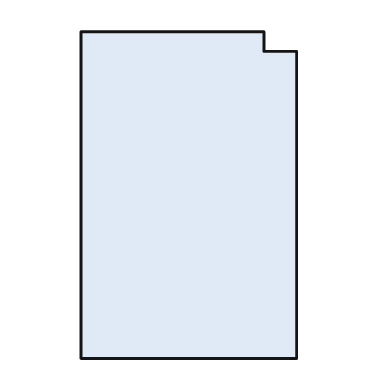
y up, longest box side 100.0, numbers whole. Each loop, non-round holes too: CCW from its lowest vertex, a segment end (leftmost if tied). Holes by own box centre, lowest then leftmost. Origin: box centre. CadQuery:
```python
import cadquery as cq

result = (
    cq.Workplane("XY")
    .moveTo(-33.0, -50.0)
    .lineTo(33.0, -50.0)
    .lineTo(33.0, 44.0)
    .lineTo(23.0, 44.0)
    .lineTo(23.0, 50.0)
    .lineTo(-33.0, 50.0)
    .close()
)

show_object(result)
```